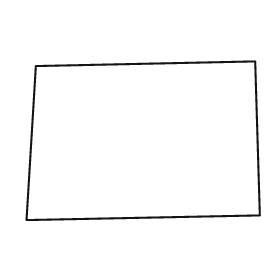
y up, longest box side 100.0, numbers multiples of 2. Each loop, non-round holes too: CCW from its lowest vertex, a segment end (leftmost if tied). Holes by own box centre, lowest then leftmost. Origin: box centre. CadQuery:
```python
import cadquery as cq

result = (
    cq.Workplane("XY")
    .moveTo(-50.0, -34.0)
    .lineTo(50.0, -32.0)
    .lineTo(48.0, 34.0)
    .lineTo(-46.0, 32.0)
    .close()
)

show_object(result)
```